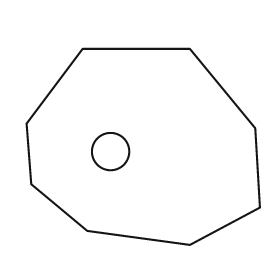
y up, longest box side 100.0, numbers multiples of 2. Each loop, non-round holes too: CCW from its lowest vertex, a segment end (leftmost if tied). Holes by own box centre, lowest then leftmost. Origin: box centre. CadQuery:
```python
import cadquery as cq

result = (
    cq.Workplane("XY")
    .moveTo(20.0, -42.0)
    .lineTo(50.0, -26.0)
    .lineTo(48.0, 8.0)
    .lineTo(20.0, 42.0)
    .lineTo(-26.0, 42.0)
    .lineTo(-50.0, 10.0)
    .lineTo(-48.0, -16.0)
    .lineTo(-24.0, -36.0)
    .close()
    .moveTo(-14.0, -2.0)
    .circle(8.0)
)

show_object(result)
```